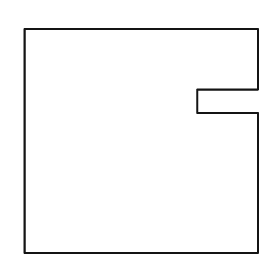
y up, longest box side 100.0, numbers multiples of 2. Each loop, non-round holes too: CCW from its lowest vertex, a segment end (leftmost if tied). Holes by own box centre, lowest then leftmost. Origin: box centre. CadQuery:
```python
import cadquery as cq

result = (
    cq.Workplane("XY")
    .moveTo(-50.0, -48.0)
    .lineTo(50.0, -48.0)
    .lineTo(50.0, 12.0)
    .lineTo(24.0, 12.0)
    .lineTo(24.0, 22.0)
    .lineTo(50.0, 22.0)
    .lineTo(50.0, 48.0)
    .lineTo(-50.0, 48.0)
    .close()
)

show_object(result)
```